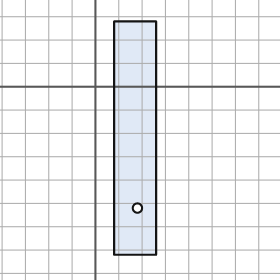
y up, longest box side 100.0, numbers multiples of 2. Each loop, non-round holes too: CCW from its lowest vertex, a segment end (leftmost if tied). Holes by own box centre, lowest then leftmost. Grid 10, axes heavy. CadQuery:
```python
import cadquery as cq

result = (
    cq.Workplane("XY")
    .moveTo(8.0, -72.0)
    .lineTo(26.0, -72.0)
    .lineTo(26.0, 28.0)
    .lineTo(8.0, 28.0)
    .close()
    .moveTo(18.0, -52.0)
    .circle(2.0)
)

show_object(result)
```